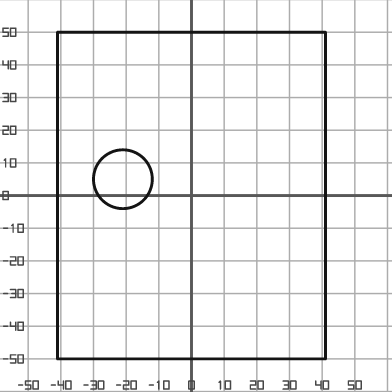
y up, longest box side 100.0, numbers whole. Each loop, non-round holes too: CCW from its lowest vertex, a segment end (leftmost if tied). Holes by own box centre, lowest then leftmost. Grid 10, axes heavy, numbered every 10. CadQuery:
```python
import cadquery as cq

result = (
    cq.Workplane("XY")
    .moveTo(-41.0, -50.0)
    .lineTo(41.0, -50.0)
    .lineTo(41.0, 50.0)
    .lineTo(-41.0, 50.0)
    .close()
    .moveTo(-21.0, 5.0)
    .circle(9.0)
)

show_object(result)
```